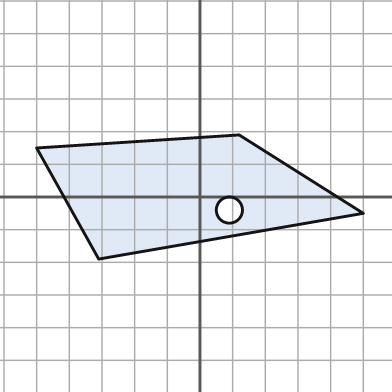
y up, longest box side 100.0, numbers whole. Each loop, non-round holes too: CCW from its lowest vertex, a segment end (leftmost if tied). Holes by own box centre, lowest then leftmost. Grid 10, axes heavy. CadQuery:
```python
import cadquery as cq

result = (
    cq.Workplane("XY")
    .moveTo(-31.0, -19.0)
    .lineTo(50.0, -5.0)
    .lineTo(12.0, 19.0)
    .lineTo(-50.0, 15.0)
    .close()
    .moveTo(9.0, -4.0)
    .circle(4.0)
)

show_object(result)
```